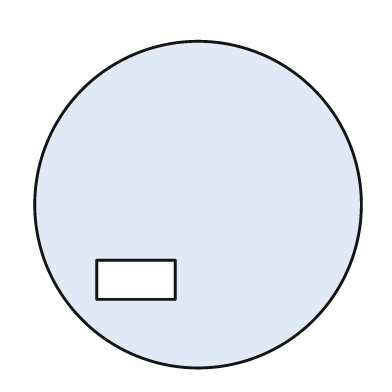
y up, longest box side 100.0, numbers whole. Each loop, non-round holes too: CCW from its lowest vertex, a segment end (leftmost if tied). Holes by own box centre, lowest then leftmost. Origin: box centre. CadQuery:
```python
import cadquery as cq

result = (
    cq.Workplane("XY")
    .moveTo(0.0, 0.0)
    .circle(50.0)
    .moveTo(-31.0, -29.0)
    .lineTo(-7.0, -29.0)
    .lineTo(-7.0, -17.0)
    .lineTo(-31.0, -17.0)
    .close()
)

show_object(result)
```